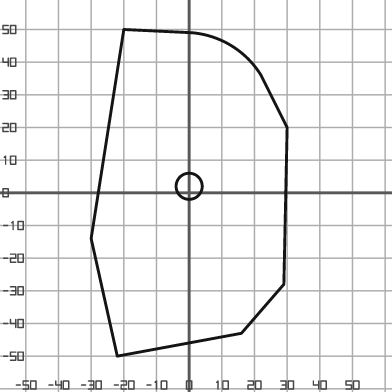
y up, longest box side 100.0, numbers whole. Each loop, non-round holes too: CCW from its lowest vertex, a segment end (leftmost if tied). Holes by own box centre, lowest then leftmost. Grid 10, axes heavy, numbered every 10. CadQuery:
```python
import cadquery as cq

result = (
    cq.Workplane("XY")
    .moveTo(-22.0, -50.0)
    .lineTo(16.0, -43.0)
    .lineTo(29.0, -28.0)
    .lineTo(30.0, 20.0)
    .lineTo(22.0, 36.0)
    .threePointArc((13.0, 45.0), (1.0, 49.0))
    .lineTo(-20.0, 50.0)
    .lineTo(-30.0, -14.0)
    .close()
    .moveTo(0.0, 2.0)
    .circle(4.0)
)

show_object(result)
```